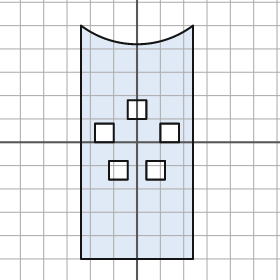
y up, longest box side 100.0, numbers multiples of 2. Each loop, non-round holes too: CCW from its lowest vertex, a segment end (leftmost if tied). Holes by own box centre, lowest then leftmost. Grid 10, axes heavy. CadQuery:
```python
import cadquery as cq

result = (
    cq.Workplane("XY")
    .moveTo(-24.0, -50.0)
    .lineTo(24.0, -50.0)
    .lineTo(24.0, 50.0)
    .threePointArc((0.0, 42.0), (-24.0, 50.0))
    .close()
    .moveTo(-12.0, -16.0)
    .lineTo(-4.0, -16.0)
    .lineTo(-4.0, -8.0)
    .lineTo(-12.0, -8.0)
    .close()
    .moveTo(4.0, -16.0)
    .lineTo(12.0, -16.0)
    .lineTo(12.0, -8.0)
    .lineTo(4.0, -8.0)
    .close()
    .moveTo(-18.0, 0.0)
    .lineTo(-10.0, 0.0)
    .lineTo(-10.0, 8.0)
    .lineTo(-18.0, 8.0)
    .close()
    .moveTo(10.0, 0.0)
    .lineTo(18.0, 0.0)
    .lineTo(18.0, 8.0)
    .lineTo(10.0, 8.0)
    .close()
    .moveTo(-4.0, 10.0)
    .lineTo(4.0, 10.0)
    .lineTo(4.0, 18.0)
    .lineTo(-4.0, 18.0)
    .close()
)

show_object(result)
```